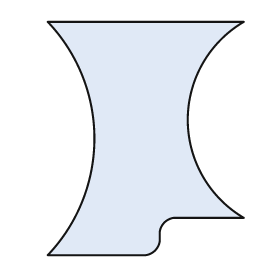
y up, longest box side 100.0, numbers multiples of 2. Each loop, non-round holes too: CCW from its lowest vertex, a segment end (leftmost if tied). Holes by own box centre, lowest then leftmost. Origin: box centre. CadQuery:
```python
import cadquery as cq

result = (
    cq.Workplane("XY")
    .moveTo(-42.0, -50.0)
    .lineTo(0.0, -50.0)
    .threePointArc((4.0, -48.0), (6.0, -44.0))
    .lineTo(6.0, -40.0)
    .threePointArc((8.0, -36.0), (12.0, -34.0))
    .lineTo(42.0, -34.0)
    .threePointArc((18.0, 8.0), (42.0, 50.0))
    .lineTo(-42.0, 50.0)
    .threePointArc((-22.0, 0.0), (-42.0, -50.0))
    .close()
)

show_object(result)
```